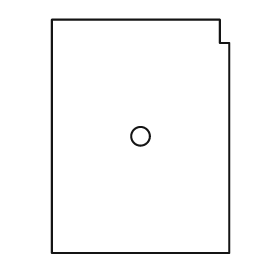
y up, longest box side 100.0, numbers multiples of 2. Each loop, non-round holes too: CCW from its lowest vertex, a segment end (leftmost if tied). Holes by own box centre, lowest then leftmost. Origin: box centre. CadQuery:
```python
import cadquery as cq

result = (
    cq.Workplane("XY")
    .moveTo(-38.0, -50.0)
    .lineTo(38.0, -50.0)
    .lineTo(38.0, 40.0)
    .lineTo(34.0, 40.0)
    .lineTo(34.0, 50.0)
    .lineTo(-38.0, 50.0)
    .close()
    .moveTo(0.0, 0.0)
    .circle(4.0)
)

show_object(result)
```